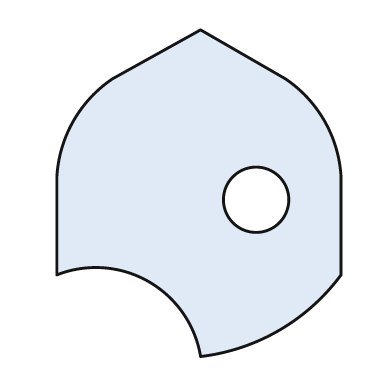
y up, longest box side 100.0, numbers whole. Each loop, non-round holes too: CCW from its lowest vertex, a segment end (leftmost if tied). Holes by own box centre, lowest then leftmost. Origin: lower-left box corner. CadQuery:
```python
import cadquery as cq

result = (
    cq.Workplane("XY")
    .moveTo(44.0, 0.0)
    .threePointArc((68.0, 8.0), (87.0, 25.0))
    .lineTo(87.0, 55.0)
    .threePointArc((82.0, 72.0), (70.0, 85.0))
    .lineTo(44.0, 100.0)
    .lineTo(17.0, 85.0)
    .threePointArc((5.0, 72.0), (0.0, 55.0))
    .lineTo(0.0, 25.0)
    .threePointArc((28.0, 23.0), (44.0, 0.0))
    .close()
    .moveTo(61.0, 48.0)
    .circle(10.0)
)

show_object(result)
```